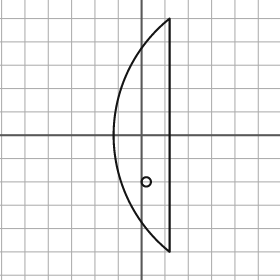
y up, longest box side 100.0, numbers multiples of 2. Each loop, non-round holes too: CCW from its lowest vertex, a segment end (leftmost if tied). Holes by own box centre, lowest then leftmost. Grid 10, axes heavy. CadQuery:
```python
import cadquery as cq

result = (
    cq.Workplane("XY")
    .moveTo(12.0, -50.0)
    .lineTo(12.0, 50.0)
    .threePointArc((-12.0, 0.0), (12.0, -50.0))
    .close()
    .moveTo(2.0, -20.0)
    .circle(2.0)
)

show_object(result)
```